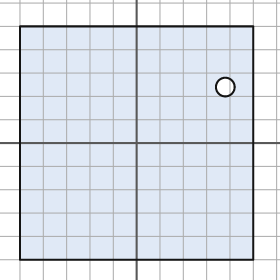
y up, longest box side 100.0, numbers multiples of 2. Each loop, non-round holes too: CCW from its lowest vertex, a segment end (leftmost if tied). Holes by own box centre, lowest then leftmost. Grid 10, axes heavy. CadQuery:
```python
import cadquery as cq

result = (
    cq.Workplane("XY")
    .moveTo(-50.0, -50.0)
    .lineTo(50.0, -50.0)
    .lineTo(50.0, 50.0)
    .lineTo(-50.0, 50.0)
    .close()
    .moveTo(38.0, 24.0)
    .circle(4.0)
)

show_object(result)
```